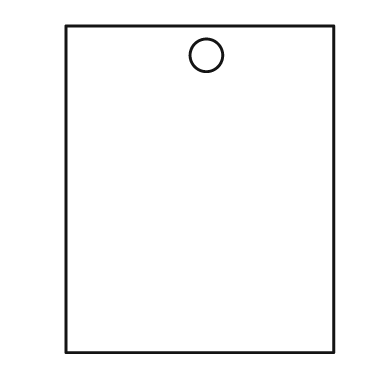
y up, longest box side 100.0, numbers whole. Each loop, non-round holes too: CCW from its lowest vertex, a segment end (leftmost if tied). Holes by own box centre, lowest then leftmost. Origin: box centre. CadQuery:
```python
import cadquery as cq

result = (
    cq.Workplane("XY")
    .moveTo(-41.0, -50.0)
    .lineTo(41.0, -50.0)
    .lineTo(41.0, 50.0)
    .lineTo(-41.0, 50.0)
    .close()
    .moveTo(2.0, 41.0)
    .circle(5.0)
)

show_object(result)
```